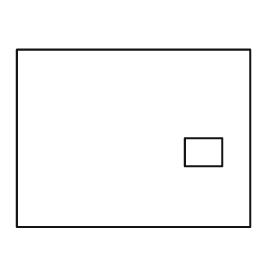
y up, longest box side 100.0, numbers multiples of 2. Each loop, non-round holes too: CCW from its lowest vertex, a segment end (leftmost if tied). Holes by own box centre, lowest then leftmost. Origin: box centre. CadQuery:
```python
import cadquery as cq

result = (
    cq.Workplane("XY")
    .moveTo(-50.0, -38.0)
    .lineTo(50.0, -38.0)
    .lineTo(50.0, 38.0)
    .lineTo(-50.0, 38.0)
    .close()
    .moveTo(22.0, -12.0)
    .lineTo(38.0, -12.0)
    .lineTo(38.0, 0.0)
    .lineTo(22.0, 0.0)
    .close()
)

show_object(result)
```